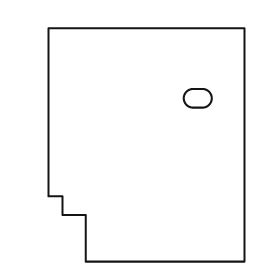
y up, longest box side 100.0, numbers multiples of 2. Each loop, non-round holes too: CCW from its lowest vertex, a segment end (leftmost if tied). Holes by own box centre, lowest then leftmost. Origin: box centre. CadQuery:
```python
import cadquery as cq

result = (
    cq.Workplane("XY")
    .moveTo(-26.0, -50.0)
    .lineTo(42.0, -50.0)
    .lineTo(42.0, 50.0)
    .lineTo(-42.0, 50.0)
    .lineTo(-42.0, -22.0)
    .lineTo(-36.0, -22.0)
    .lineTo(-36.0, -30.0)
    .lineTo(-26.0, -30.0)
    .close()
    .moveTo(20.0, 16.0)
    .lineTo(24.0, 16.0)
    .threePointArc((28.0, 20.0), (24.0, 24.0))
    .lineTo(20.0, 24.0)
    .threePointArc((16.0, 20.0), (20.0, 16.0))
    .close()
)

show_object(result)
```